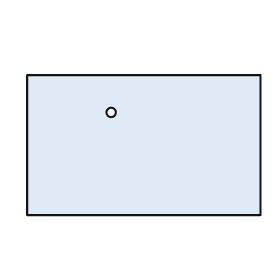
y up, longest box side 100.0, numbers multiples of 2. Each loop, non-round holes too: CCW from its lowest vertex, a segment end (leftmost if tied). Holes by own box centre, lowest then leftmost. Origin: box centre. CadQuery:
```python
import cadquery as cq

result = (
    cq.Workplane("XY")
    .moveTo(-50.0, -30.0)
    .lineTo(50.0, -30.0)
    .lineTo(50.0, 30.0)
    .lineTo(-50.0, 30.0)
    .close()
    .moveTo(-14.0, 14.0)
    .circle(2.0)
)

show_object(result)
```